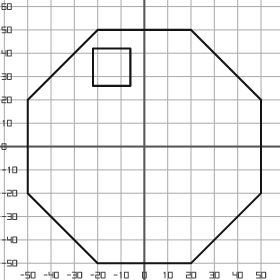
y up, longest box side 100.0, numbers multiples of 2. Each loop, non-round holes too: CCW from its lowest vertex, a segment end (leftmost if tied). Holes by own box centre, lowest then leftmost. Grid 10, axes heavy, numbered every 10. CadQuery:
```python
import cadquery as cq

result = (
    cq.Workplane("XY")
    .moveTo(-20.0, -50.0)
    .lineTo(20.0, -50.0)
    .lineTo(50.0, -20.0)
    .lineTo(50.0, 20.0)
    .lineTo(20.0, 50.0)
    .lineTo(-20.0, 50.0)
    .lineTo(-50.0, 20.0)
    .lineTo(-50.0, -20.0)
    .close()
    .moveTo(-22.0, 26.0)
    .lineTo(-6.0, 26.0)
    .lineTo(-6.0, 42.0)
    .lineTo(-22.0, 42.0)
    .close()
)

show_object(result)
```